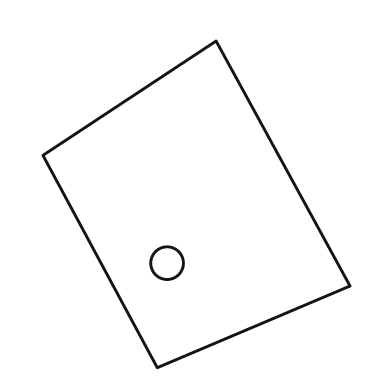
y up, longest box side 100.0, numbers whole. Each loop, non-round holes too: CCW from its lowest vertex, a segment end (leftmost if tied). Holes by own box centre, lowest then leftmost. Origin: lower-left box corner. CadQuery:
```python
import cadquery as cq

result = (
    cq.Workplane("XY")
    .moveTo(35.0, 0.0)
    .lineTo(94.0, 25.0)
    .lineTo(53.0, 100.0)
    .lineTo(0.0, 65.0)
    .close()
    .moveTo(38.0, 32.0)
    .circle(5.0)
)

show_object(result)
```